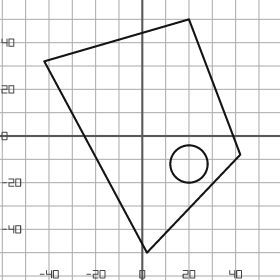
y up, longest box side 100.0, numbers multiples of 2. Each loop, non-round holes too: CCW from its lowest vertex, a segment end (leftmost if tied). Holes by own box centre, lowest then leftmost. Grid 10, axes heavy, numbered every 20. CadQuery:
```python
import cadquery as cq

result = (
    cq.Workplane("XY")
    .moveTo(2.0, -50.0)
    .lineTo(42.0, -8.0)
    .lineTo(20.0, 50.0)
    .lineTo(-42.0, 32.0)
    .close()
    .moveTo(20.0, -12.0)
    .circle(8.0)
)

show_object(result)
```